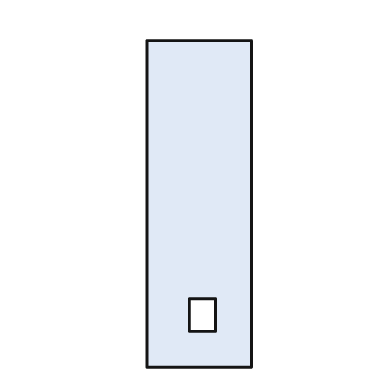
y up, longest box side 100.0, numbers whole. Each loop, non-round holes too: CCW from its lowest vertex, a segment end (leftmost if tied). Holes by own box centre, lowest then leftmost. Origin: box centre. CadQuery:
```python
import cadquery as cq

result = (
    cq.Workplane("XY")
    .moveTo(-16.0, -50.0)
    .lineTo(16.0, -50.0)
    .lineTo(16.0, 50.0)
    .lineTo(-16.0, 50.0)
    .close()
    .moveTo(-3.0, -39.0)
    .lineTo(5.0, -39.0)
    .lineTo(5.0, -29.0)
    .lineTo(-3.0, -29.0)
    .close()
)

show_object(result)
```